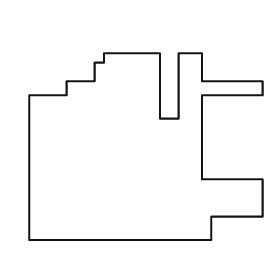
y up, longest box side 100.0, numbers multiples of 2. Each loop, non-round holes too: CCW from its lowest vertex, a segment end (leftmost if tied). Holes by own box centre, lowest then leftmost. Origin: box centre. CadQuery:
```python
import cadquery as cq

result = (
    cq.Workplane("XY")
    .moveTo(-50.0, -40.0)
    .lineTo(28.0, -40.0)
    .lineTo(28.0, -30.0)
    .lineTo(50.0, -30.0)
    .lineTo(50.0, -14.0)
    .lineTo(24.0, -14.0)
    .lineTo(24.0, 22.0)
    .lineTo(50.0, 22.0)
    .lineTo(50.0, 28.0)
    .lineTo(24.0, 28.0)
    .lineTo(24.0, 40.0)
    .lineTo(14.0, 40.0)
    .lineTo(14.0, 12.0)
    .lineTo(6.0, 12.0)
    .lineTo(6.0, 40.0)
    .lineTo(-18.0, 40.0)
    .lineTo(-18.0, 36.0)
    .lineTo(-22.0, 36.0)
    .lineTo(-22.0, 28.0)
    .lineTo(-34.0, 28.0)
    .lineTo(-34.0, 22.0)
    .lineTo(-50.0, 22.0)
    .close()
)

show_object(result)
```